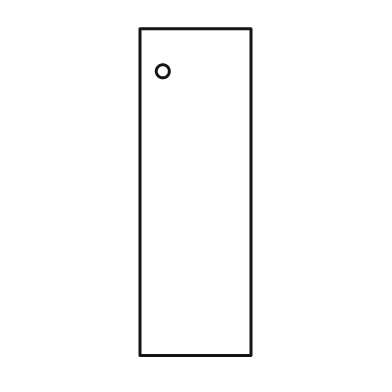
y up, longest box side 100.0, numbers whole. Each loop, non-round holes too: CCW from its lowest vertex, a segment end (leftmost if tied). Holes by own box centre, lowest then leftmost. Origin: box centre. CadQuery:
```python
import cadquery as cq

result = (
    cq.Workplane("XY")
    .moveTo(-17.0, -50.0)
    .lineTo(17.0, -50.0)
    .lineTo(17.0, 50.0)
    .lineTo(-17.0, 50.0)
    .close()
    .moveTo(-10.0, 37.0)
    .circle(2.0)
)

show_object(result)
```